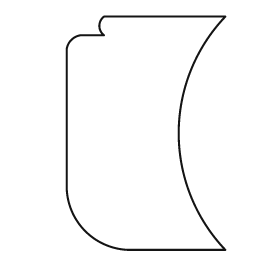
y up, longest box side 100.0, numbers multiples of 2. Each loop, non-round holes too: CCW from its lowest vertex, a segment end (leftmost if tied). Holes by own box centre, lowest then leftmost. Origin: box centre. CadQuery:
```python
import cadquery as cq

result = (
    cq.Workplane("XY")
    .moveTo(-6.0, -50.0)
    .lineTo(34.0, -50.0)
    .threePointArc((14.0, 0.0), (34.0, 50.0))
    .lineTo(-18.0, 50.0)
    .threePointArc((-20.0, 46.0), (-18.0, 42.0))
    .lineTo(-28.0, 42.0)
    .threePointArc((-32.0, 40.0), (-34.0, 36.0))
    .lineTo(-34.0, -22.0)
    .threePointArc((-26.0, -42.0), (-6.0, -50.0))
    .close()
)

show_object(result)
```